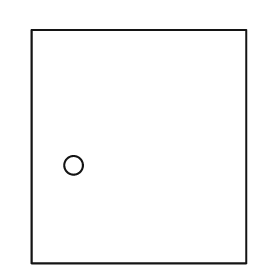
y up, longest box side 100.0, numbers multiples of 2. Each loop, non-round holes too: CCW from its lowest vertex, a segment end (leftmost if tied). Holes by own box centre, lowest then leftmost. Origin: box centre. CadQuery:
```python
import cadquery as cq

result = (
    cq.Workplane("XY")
    .moveTo(-46.0, -50.0)
    .lineTo(46.0, -50.0)
    .lineTo(46.0, 50.0)
    .lineTo(-46.0, 50.0)
    .close()
    .moveTo(-28.0, -8.0)
    .circle(4.0)
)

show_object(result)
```